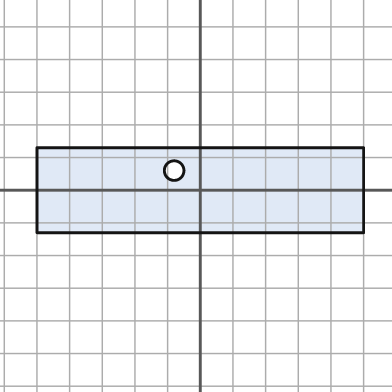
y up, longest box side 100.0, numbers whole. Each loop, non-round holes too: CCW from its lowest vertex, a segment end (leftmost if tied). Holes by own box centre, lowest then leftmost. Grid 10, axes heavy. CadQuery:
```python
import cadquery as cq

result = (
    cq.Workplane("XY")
    .moveTo(-50.0, -13.0)
    .lineTo(50.0, -13.0)
    .lineTo(50.0, 13.0)
    .lineTo(-50.0, 13.0)
    .close()
    .moveTo(-8.0, 6.0)
    .circle(3.0)
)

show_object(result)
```